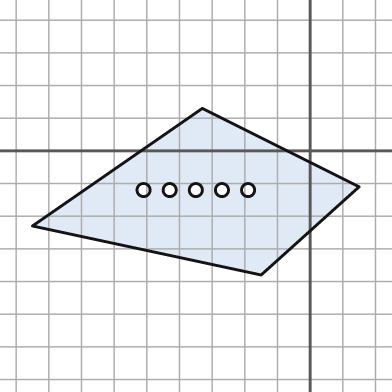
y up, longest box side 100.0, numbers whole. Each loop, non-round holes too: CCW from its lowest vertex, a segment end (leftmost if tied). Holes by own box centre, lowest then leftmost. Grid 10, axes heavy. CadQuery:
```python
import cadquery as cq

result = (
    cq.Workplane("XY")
    .moveTo(-15.0, -38.0)
    .lineTo(15.0, -11.0)
    .lineTo(-33.0, 13.0)
    .lineTo(-85.0, -23.0)
    .close()
    .moveTo(-51.0, -12.0)
    .circle(2.0)
    .moveTo(-43.0, -12.0)
    .circle(2.0)
    .moveTo(-35.0, -12.0)
    .circle(2.0)
    .moveTo(-27.0, -12.0)
    .circle(2.0)
    .moveTo(-19.0, -12.0)
    .circle(2.0)
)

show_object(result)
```